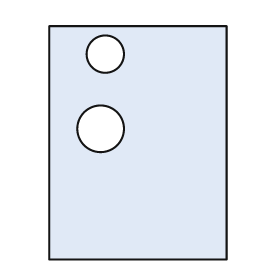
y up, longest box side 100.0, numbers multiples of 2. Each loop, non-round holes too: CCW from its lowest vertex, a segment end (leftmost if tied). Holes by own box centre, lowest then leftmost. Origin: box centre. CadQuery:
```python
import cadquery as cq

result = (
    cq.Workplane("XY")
    .moveTo(-38.0, -50.0)
    .lineTo(38.0, -50.0)
    .lineTo(38.0, 50.0)
    .lineTo(-38.0, 50.0)
    .close()
    .moveTo(-16.0, 6.0)
    .circle(10.0)
    .moveTo(-14.0, 38.0)
    .circle(8.0)
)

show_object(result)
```